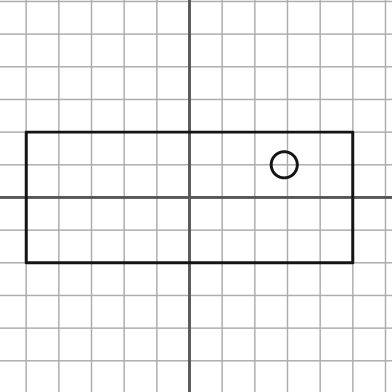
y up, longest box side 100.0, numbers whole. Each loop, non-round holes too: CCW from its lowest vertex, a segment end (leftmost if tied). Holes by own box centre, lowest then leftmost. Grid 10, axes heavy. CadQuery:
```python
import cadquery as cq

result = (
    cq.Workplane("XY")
    .moveTo(-50.0, -20.0)
    .lineTo(50.0, -20.0)
    .lineTo(50.0, 20.0)
    .lineTo(-50.0, 20.0)
    .close()
    .moveTo(29.0, 10.0)
    .circle(4.0)
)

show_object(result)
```